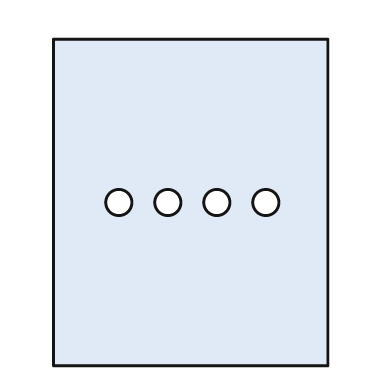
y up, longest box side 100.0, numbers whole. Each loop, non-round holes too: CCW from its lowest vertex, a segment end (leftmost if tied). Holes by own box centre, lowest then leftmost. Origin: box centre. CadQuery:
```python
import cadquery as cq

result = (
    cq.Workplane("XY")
    .moveTo(-42.0, -50.0)
    .lineTo(42.0, -50.0)
    .lineTo(42.0, 50.0)
    .lineTo(-42.0, 50.0)
    .close()
    .moveTo(-22.0, 0.0)
    .circle(4.0)
    .moveTo(-7.0, 0.0)
    .circle(4.0)
    .moveTo(8.0, 0.0)
    .circle(4.0)
    .moveTo(23.0, 0.0)
    .circle(4.0)
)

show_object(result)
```